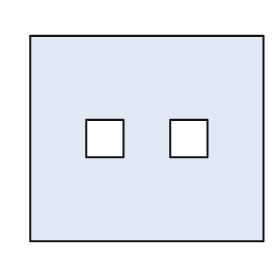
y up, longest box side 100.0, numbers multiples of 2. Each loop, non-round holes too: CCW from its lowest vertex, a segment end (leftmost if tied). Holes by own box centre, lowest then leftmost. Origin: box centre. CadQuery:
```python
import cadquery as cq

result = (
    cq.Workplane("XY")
    .moveTo(-50.0, -44.0)
    .lineTo(50.0, -44.0)
    .lineTo(50.0, 44.0)
    .lineTo(-50.0, 44.0)
    .close()
    .moveTo(-26.0, -8.0)
    .lineTo(-10.0, -8.0)
    .lineTo(-10.0, 8.0)
    .lineTo(-26.0, 8.0)
    .close()
    .moveTo(10.0, -8.0)
    .lineTo(26.0, -8.0)
    .lineTo(26.0, 8.0)
    .lineTo(10.0, 8.0)
    .close()
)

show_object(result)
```